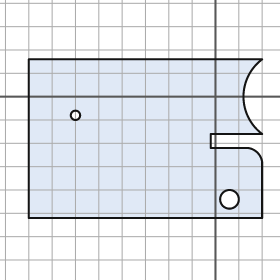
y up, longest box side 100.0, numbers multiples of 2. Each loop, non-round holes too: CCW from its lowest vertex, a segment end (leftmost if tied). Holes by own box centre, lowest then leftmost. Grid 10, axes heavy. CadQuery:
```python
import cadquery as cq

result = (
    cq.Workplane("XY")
    .moveTo(-80.0, -52.0)
    .lineTo(20.0, -52.0)
    .lineTo(20.0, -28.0)
    .threePointArc((18.0, -24.0), (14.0, -22.0))
    .lineTo(-2.0, -22.0)
    .lineTo(-2.0, -16.0)
    .lineTo(20.0, -16.0)
    .threePointArc((12.0, 0.0), (20.0, 16.0))
    .lineTo(-80.0, 16.0)
    .close()
    .moveTo(6.0, -44.0)
    .circle(4.0)
    .moveTo(-60.0, -8.0)
    .circle(2.0)
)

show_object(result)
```